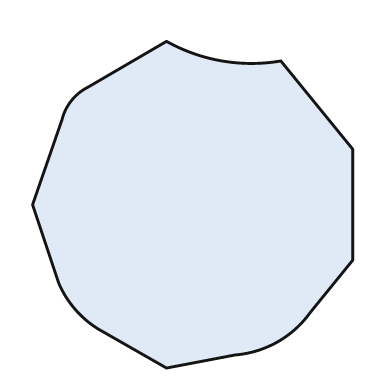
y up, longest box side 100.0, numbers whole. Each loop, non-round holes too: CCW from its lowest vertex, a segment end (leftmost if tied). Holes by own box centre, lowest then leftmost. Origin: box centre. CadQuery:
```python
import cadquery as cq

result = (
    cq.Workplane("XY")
    .moveTo(-8.0, -50.0)
    .lineTo(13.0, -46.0)
    .threePointArc((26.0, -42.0), (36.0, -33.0))
    .lineTo(49.0, -17.0)
    .lineTo(49.0, 17.0)
    .lineTo(27.0, 44.0)
    .threePointArc((9.0, 44.0), (-8.0, 50.0))
    .lineTo(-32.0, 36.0)
    .threePointArc((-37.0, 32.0), (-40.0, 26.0))
    .lineTo(-49.0, 0.0)
    .lineTo(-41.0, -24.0)
    .threePointArc((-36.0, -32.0), (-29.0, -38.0))
    .close()
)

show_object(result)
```